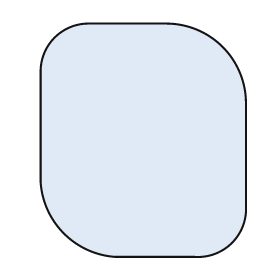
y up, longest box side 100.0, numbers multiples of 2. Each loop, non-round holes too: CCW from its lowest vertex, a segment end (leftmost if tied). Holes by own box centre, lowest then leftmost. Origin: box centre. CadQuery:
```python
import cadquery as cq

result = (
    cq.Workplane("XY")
    .moveTo(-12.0, -50.0)
    .lineTo(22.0, -50.0)
    .threePointArc((38.0, -44.0), (44.0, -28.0))
    .lineTo(44.0, 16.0)
    .threePointArc((34.0, 40.0), (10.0, 50.0))
    .lineTo(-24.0, 50.0)
    .threePointArc((-38.0, 44.0), (-44.0, 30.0))
    .lineTo(-44.0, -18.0)
    .threePointArc((-34.0, -40.0), (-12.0, -50.0))
    .close()
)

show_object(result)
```